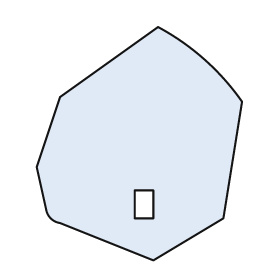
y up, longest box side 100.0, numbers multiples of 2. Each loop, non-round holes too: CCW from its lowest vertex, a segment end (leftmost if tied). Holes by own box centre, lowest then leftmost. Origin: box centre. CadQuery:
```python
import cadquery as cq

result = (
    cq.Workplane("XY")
    .moveTo(6.0, -50.0)
    .lineTo(36.0, -32.0)
    .lineTo(44.0, 18.0)
    .threePointArc((28.0, 36.0), (8.0, 50.0))
    .lineTo(-34.0, 20.0)
    .lineTo(-44.0, -10.0)
    .lineTo(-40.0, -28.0)
    .threePointArc((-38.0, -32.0), (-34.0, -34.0))
    .close()
    .moveTo(-2.0, -32.0)
    .lineTo(6.0, -32.0)
    .lineTo(6.0, -20.0)
    .lineTo(-2.0, -20.0)
    .close()
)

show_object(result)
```